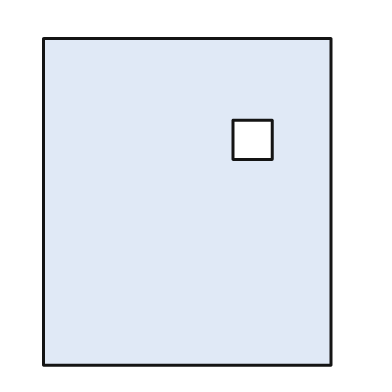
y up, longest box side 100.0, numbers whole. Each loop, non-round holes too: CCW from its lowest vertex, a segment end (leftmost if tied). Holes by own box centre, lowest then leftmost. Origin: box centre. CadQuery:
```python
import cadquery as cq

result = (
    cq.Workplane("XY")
    .moveTo(-44.0, -50.0)
    .lineTo(44.0, -50.0)
    .lineTo(44.0, 50.0)
    .lineTo(-44.0, 50.0)
    .close()
    .moveTo(14.0, 13.0)
    .lineTo(26.0, 13.0)
    .lineTo(26.0, 25.0)
    .lineTo(14.0, 25.0)
    .close()
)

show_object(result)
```